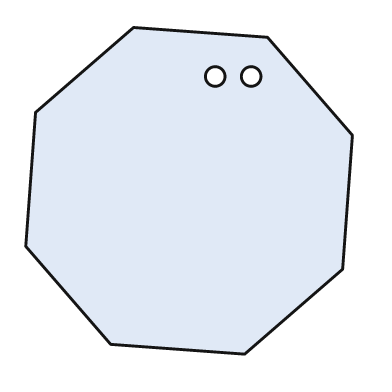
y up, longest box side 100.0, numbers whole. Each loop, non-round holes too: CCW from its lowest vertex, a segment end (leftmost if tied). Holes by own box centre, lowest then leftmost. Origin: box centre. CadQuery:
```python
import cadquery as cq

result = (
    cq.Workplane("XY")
    .moveTo(17.0, -50.0)
    .lineTo(47.0, -24.0)
    .lineTo(50.0, 17.0)
    .lineTo(24.0, 47.0)
    .lineTo(-17.0, 50.0)
    .lineTo(-47.0, 24.0)
    .lineTo(-50.0, -17.0)
    .lineTo(-24.0, -47.0)
    .close()
    .moveTo(8.0, 35.0)
    .circle(3.0)
    .moveTo(19.0, 35.0)
    .circle(3.0)
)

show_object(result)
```